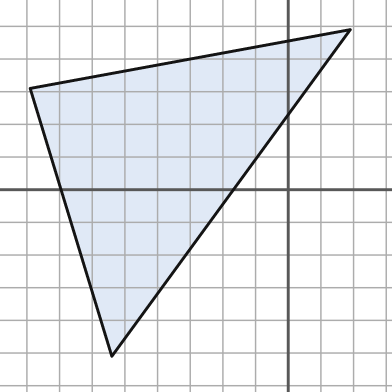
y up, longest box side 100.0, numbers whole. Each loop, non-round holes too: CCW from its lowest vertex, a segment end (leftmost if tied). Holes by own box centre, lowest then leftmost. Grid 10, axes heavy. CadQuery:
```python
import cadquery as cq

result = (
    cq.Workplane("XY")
    .moveTo(-54.0, -51.0)
    .lineTo(19.0, 49.0)
    .lineTo(-79.0, 31.0)
    .close()
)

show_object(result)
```